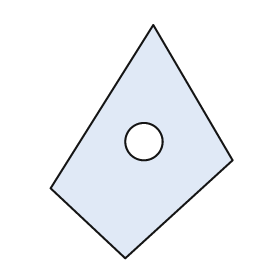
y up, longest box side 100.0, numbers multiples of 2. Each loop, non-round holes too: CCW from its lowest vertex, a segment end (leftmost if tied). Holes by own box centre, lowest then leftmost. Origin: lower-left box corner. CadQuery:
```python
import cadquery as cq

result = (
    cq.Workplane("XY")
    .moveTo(32.0, 0.0)
    .lineTo(78.0, 42.0)
    .lineTo(44.0, 100.0)
    .lineTo(0.0, 30.0)
    .close()
    .moveTo(40.0, 50.0)
    .circle(8.0)
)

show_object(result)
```